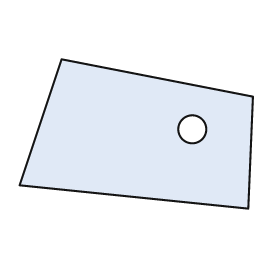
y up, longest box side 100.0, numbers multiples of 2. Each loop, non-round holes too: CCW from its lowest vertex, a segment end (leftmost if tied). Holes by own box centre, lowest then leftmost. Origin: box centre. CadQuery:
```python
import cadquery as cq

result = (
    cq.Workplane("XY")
    .moveTo(48.0, -32.0)
    .lineTo(50.0, 16.0)
    .lineTo(-32.0, 32.0)
    .lineTo(-50.0, -22.0)
    .close()
    .moveTo(24.0, 2.0)
    .circle(6.0)
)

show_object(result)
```